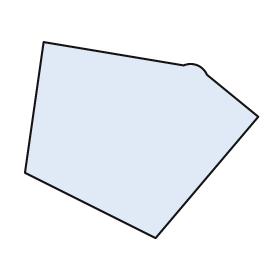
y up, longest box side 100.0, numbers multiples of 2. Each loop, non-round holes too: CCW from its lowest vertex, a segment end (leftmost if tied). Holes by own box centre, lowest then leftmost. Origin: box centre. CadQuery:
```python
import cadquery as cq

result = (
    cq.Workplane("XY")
    .moveTo(6.0, -42.0)
    .lineTo(50.0, 10.0)
    .lineTo(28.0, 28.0)
    .threePointArc((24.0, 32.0), (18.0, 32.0))
    .lineTo(-42.0, 42.0)
    .lineTo(-50.0, -14.0)
    .close()
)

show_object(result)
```